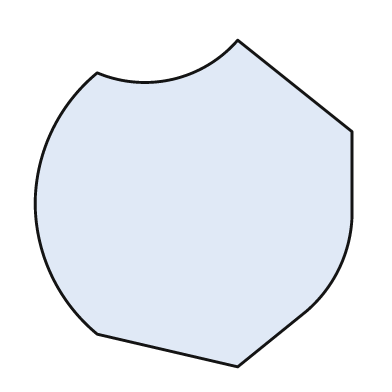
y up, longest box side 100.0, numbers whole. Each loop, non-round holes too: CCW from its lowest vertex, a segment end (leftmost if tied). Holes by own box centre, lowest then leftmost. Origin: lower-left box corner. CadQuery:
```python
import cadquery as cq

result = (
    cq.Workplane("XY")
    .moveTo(62.0, 0.0)
    .lineTo(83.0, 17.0)
    .threePointArc((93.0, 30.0), (97.0, 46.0))
    .lineTo(97.0, 72.0)
    .lineTo(62.0, 100.0)
    .threePointArc((42.0, 88.0), (19.0, 90.0))
    .threePointArc((5.0, 72.0), (0.0, 50.0))
    .threePointArc((5.0, 28.0), (19.0, 10.0))
    .close()
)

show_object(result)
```